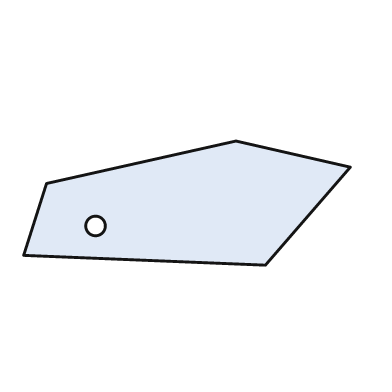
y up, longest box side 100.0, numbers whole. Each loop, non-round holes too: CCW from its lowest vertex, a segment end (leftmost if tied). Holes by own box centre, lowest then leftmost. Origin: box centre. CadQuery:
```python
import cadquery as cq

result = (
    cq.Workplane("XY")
    .moveTo(24.0, -19.0)
    .lineTo(50.0, 11.0)
    .lineTo(15.0, 19.0)
    .lineTo(-43.0, 6.0)
    .lineTo(-50.0, -16.0)
    .close()
    .moveTo(-28.0, -7.0)
    .circle(3.0)
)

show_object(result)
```